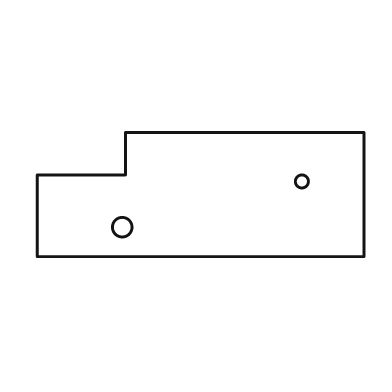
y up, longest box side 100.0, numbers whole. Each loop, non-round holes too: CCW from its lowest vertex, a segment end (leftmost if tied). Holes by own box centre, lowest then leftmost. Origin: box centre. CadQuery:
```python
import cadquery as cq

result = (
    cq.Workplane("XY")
    .moveTo(-50.0, -19.0)
    .lineTo(50.0, -19.0)
    .lineTo(50.0, 19.0)
    .lineTo(-23.0, 19.0)
    .lineTo(-23.0, 6.0)
    .lineTo(-50.0, 6.0)
    .close()
    .moveTo(-24.0, -10.0)
    .circle(3.0)
    .moveTo(31.0, 4.0)
    .circle(2.0)
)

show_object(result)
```